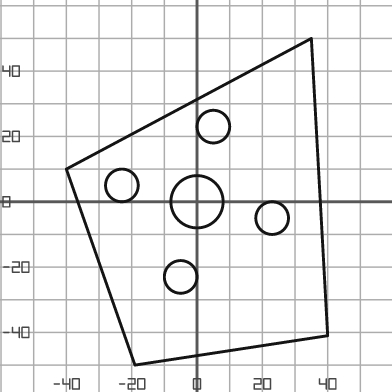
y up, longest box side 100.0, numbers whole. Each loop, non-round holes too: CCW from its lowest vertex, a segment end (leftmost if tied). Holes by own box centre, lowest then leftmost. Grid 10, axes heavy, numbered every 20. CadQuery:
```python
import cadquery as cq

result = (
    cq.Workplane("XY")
    .moveTo(-19.0, -50.0)
    .lineTo(40.0, -41.0)
    .lineTo(35.0, 50.0)
    .lineTo(-40.0, 10.0)
    .close()
    .moveTo(-5.0, -23.0)
    .circle(5.0)
    .moveTo(23.0, -5.0)
    .circle(5.0)
    .moveTo(0.0, 0.0)
    .circle(8.0)
    .moveTo(-23.0, 5.0)
    .circle(5.0)
    .moveTo(5.0, 23.0)
    .circle(5.0)
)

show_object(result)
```